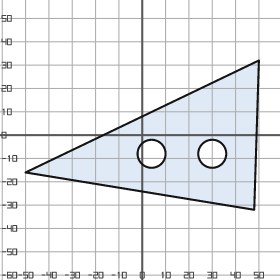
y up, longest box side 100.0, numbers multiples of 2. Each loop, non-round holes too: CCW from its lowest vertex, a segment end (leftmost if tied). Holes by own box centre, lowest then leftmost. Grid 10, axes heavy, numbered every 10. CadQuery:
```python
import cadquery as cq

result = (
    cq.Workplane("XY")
    .moveTo(48.0, -32.0)
    .lineTo(50.0, 32.0)
    .lineTo(-50.0, -16.0)
    .close()
    .moveTo(4.0, -8.0)
    .circle(6.0)
    .moveTo(30.0, -8.0)
    .circle(6.0)
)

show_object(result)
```